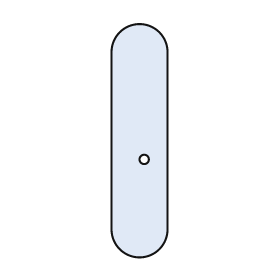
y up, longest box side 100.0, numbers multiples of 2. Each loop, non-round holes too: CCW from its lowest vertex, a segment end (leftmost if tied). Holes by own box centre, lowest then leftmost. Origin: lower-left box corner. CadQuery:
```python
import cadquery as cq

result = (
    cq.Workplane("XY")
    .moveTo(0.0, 12.0)
    .threePointArc((12.0, 0.0), (24.0, 12.0))
    .lineTo(24.0, 88.0)
    .threePointArc((12.0, 100.0), (0.0, 88.0))
    .close()
    .moveTo(14.0, 42.0)
    .circle(2.0)
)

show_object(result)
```